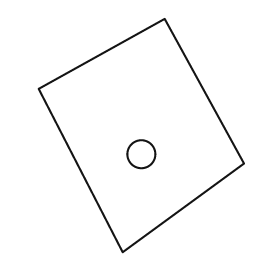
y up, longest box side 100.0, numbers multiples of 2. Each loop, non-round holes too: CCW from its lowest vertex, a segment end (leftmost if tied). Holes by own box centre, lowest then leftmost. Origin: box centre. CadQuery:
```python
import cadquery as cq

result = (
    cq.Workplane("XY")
    .moveTo(-8.0, -50.0)
    .lineTo(44.0, -12.0)
    .lineTo(10.0, 50.0)
    .lineTo(-44.0, 20.0)
    .close()
    .moveTo(0.0, -8.0)
    .circle(6.0)
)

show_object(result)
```